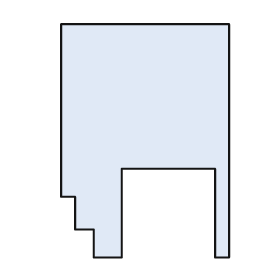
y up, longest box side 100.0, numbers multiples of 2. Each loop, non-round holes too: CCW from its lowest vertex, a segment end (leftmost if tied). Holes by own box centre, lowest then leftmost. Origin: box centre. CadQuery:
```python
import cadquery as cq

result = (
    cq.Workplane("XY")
    .moveTo(-22.0, -50.0)
    .lineTo(-10.0, -50.0)
    .lineTo(-10.0, -12.0)
    .lineTo(30.0, -12.0)
    .lineTo(30.0, -50.0)
    .lineTo(36.0, -50.0)
    .lineTo(36.0, 50.0)
    .lineTo(-36.0, 50.0)
    .lineTo(-36.0, -24.0)
    .lineTo(-30.0, -24.0)
    .lineTo(-30.0, -38.0)
    .lineTo(-22.0, -38.0)
    .close()
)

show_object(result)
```